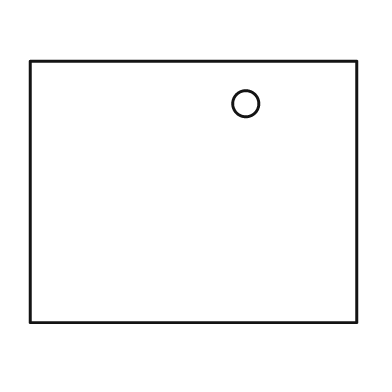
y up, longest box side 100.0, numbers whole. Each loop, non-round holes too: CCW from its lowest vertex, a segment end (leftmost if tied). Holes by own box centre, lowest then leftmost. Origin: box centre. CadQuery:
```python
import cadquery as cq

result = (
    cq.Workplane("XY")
    .moveTo(-50.0, -40.0)
    .lineTo(50.0, -40.0)
    .lineTo(50.0, 40.0)
    .lineTo(-50.0, 40.0)
    .close()
    .moveTo(16.0, 27.0)
    .circle(4.0)
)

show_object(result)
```